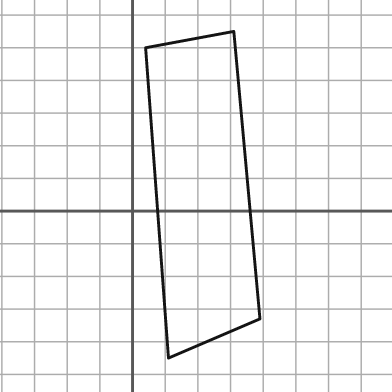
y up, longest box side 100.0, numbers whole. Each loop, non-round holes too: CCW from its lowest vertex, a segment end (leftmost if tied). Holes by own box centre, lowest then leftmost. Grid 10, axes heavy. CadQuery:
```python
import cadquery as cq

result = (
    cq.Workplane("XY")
    .moveTo(11.0, -45.0)
    .lineTo(39.0, -33.0)
    .lineTo(31.0, 55.0)
    .lineTo(4.0, 50.0)
    .close()
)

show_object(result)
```